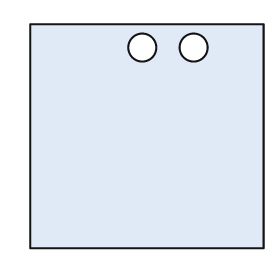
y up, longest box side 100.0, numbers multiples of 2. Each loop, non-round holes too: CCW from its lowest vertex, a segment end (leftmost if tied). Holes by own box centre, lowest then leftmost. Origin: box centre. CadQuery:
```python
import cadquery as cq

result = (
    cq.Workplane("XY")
    .moveTo(-50.0, -48.0)
    .lineTo(50.0, -48.0)
    .lineTo(50.0, 48.0)
    .lineTo(-50.0, 48.0)
    .close()
    .moveTo(-2.0, 38.0)
    .circle(6.0)
    .moveTo(20.0, 38.0)
    .circle(6.0)
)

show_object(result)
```